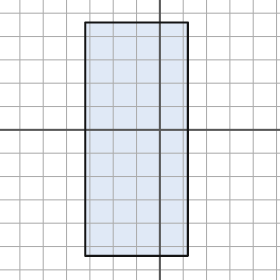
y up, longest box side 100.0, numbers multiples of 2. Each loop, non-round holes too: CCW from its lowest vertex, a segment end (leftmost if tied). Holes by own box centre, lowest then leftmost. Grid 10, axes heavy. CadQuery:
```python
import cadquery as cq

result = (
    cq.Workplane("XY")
    .moveTo(-32.0, -54.0)
    .lineTo(12.0, -54.0)
    .lineTo(12.0, 46.0)
    .lineTo(-32.0, 46.0)
    .close()
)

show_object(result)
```